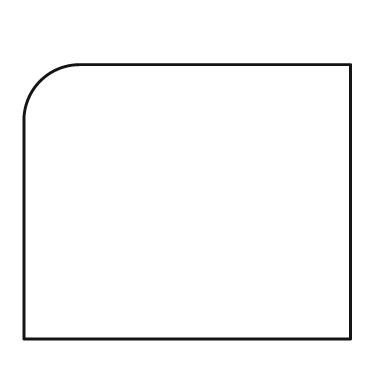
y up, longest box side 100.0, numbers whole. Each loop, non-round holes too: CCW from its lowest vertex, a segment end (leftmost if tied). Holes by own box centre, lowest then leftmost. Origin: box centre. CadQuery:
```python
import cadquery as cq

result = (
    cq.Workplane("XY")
    .moveTo(-50.0, -42.0)
    .lineTo(50.0, -42.0)
    .lineTo(50.0, 42.0)
    .lineTo(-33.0, 42.0)
    .threePointArc((-45.0, 37.0), (-50.0, 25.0))
    .close()
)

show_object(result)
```